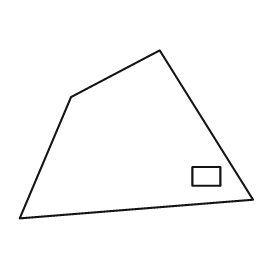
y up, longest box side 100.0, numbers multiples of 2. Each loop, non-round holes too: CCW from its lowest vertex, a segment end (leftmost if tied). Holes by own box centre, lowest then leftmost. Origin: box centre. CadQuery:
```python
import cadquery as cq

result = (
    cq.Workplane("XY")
    .moveTo(-50.0, -36.0)
    .lineTo(50.0, -28.0)
    .lineTo(10.0, 36.0)
    .lineTo(-28.0, 16.0)
    .close()
    .moveTo(24.0, -22.0)
    .lineTo(36.0, -22.0)
    .lineTo(36.0, -14.0)
    .lineTo(24.0, -14.0)
    .close()
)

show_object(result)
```